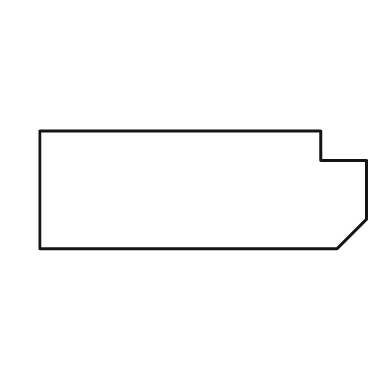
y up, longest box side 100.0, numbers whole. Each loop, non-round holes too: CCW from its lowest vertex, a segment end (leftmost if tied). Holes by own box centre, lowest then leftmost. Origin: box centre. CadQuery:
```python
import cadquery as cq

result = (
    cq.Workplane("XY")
    .moveTo(-50.0, -18.0)
    .lineTo(41.0, -18.0)
    .lineTo(50.0, -9.0)
    .lineTo(50.0, 9.0)
    .lineTo(36.0, 9.0)
    .lineTo(36.0, 18.0)
    .lineTo(-50.0, 18.0)
    .close()
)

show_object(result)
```